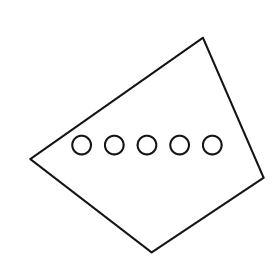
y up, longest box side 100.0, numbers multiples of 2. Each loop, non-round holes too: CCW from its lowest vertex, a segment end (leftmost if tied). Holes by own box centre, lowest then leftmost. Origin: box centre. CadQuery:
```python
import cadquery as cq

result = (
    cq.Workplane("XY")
    .moveTo(2.0, -46.0)
    .lineTo(50.0, -14.0)
    .lineTo(24.0, 46.0)
    .lineTo(-50.0, -6.0)
    .close()
    .moveTo(-28.0, 0.0)
    .circle(4.0)
    .moveTo(-14.0, 0.0)
    .circle(4.0)
    .moveTo(0.0, 0.0)
    .circle(4.0)
    .moveTo(14.0, 0.0)
    .circle(4.0)
    .moveTo(28.0, 0.0)
    .circle(4.0)
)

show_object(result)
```